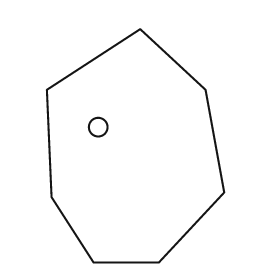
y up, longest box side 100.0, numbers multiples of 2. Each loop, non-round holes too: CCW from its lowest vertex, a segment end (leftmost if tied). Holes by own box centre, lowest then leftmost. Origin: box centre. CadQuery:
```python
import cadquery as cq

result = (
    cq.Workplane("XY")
    .moveTo(-18.0, -50.0)
    .lineTo(10.0, -50.0)
    .lineTo(38.0, -20.0)
    .lineTo(30.0, 24.0)
    .lineTo(2.0, 50.0)
    .lineTo(-38.0, 24.0)
    .lineTo(-36.0, -22.0)
    .close()
    .moveTo(-16.0, 8.0)
    .circle(4.0)
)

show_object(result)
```